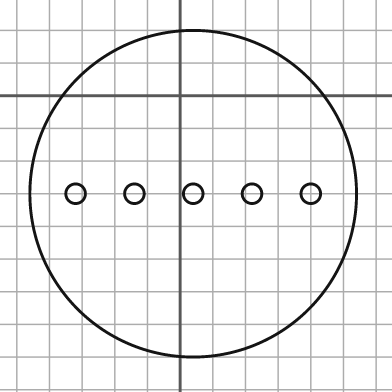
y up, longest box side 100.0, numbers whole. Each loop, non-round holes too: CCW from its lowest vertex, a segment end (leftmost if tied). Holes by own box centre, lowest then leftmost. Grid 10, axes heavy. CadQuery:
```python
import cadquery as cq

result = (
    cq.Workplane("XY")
    .moveTo(4.0, -30.0)
    .circle(50.0)
    .moveTo(-32.0, -30.0)
    .circle(3.0)
    .moveTo(-14.0, -30.0)
    .circle(3.0)
    .moveTo(4.0, -30.0)
    .circle(3.0)
    .moveTo(22.0, -30.0)
    .circle(3.0)
    .moveTo(40.0, -30.0)
    .circle(3.0)
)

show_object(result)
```